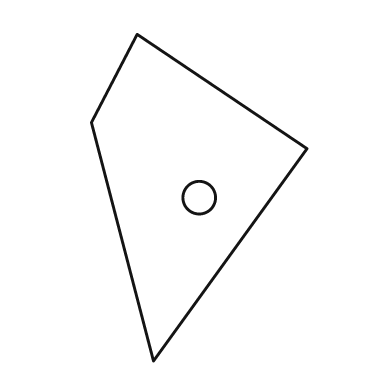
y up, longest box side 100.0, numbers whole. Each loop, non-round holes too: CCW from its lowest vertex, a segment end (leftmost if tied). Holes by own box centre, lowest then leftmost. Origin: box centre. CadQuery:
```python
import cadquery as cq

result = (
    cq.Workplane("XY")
    .moveTo(-14.0, -50.0)
    .lineTo(33.0, 15.0)
    .lineTo(-19.0, 50.0)
    .lineTo(-33.0, 23.0)
    .close()
    .moveTo(0.0, 0.0)
    .circle(5.0)
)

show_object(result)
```